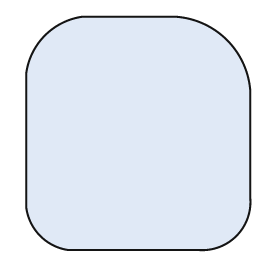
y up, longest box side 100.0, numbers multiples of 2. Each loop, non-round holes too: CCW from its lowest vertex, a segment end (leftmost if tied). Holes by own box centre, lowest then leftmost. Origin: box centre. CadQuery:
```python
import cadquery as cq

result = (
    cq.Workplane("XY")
    .moveTo(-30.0, -50.0)
    .lineTo(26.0, -50.0)
    .threePointArc((42.0, -44.0), (48.0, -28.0))
    .lineTo(48.0, 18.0)
    .threePointArc((38.0, 40.0), (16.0, 50.0))
    .lineTo(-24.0, 50.0)
    .threePointArc((-40.0, 42.0), (-48.0, 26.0))
    .lineTo(-48.0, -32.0)
    .threePointArc((-42.0, -44.0), (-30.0, -50.0))
    .close()
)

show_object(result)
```